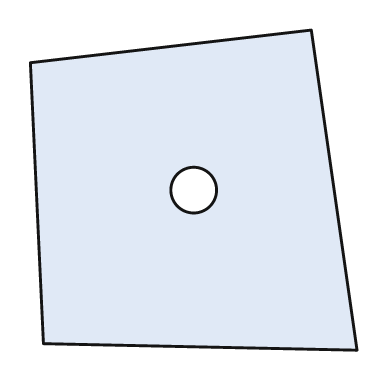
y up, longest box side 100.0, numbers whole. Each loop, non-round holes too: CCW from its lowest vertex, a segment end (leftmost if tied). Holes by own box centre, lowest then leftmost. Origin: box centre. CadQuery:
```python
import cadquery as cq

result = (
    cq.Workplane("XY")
    .moveTo(50.0, -49.0)
    .lineTo(36.0, 49.0)
    .lineTo(-50.0, 39.0)
    .lineTo(-46.0, -47.0)
    .close()
    .moveTo(0.0, 0.0)
    .circle(7.0)
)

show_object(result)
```